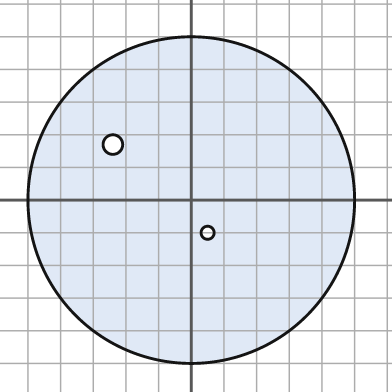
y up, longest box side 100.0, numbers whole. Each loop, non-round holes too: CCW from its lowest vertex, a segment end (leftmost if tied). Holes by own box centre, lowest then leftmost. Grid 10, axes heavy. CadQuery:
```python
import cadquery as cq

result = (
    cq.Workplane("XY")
    .moveTo(0.0, 0.0)
    .circle(50.0)
    .moveTo(5.0, -10.0)
    .circle(2.0)
    .moveTo(-24.0, 17.0)
    .circle(3.0)
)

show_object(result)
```